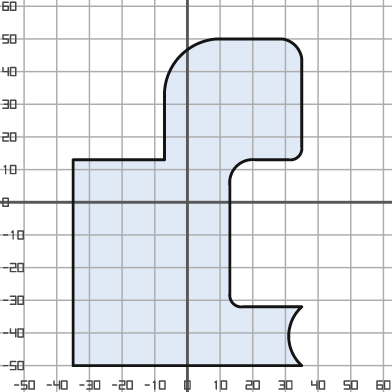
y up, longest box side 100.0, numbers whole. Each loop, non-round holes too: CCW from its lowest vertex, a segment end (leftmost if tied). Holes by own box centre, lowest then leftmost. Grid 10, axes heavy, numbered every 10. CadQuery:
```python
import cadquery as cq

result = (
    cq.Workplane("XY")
    .moveTo(-35.0, -50.0)
    .lineTo(35.0, -50.0)
    .threePointArc((31.0, -41.0), (35.0, -32.0))
    .lineTo(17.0, -32.0)
    .threePointArc((14.0, -31.0), (13.0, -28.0))
    .lineTo(13.0, 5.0)
    .threePointArc((15.0, 11.0), (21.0, 13.0))
    .lineTo(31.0, 13.0)
    .threePointArc((34.0, 14.0), (35.0, 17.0))
    .lineTo(35.0, 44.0)
    .threePointArc((33.0, 48.0), (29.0, 50.0))
    .lineTo(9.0, 50.0)
    .threePointArc((-2.0, 45.0), (-7.0, 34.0))
    .lineTo(-7.0, 13.0)
    .lineTo(-35.0, 13.0)
    .close()
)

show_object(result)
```